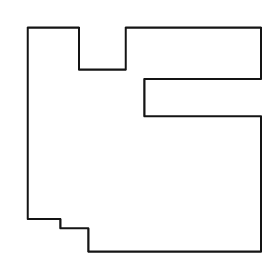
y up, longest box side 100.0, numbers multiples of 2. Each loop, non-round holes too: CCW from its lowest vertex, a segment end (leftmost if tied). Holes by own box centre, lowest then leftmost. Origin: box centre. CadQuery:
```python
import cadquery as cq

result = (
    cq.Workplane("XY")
    .moveTo(-24.0, -48.0)
    .lineTo(50.0, -48.0)
    .lineTo(50.0, 10.0)
    .lineTo(0.0, 10.0)
    .lineTo(0.0, 26.0)
    .lineTo(50.0, 26.0)
    .lineTo(50.0, 48.0)
    .lineTo(-8.0, 48.0)
    .lineTo(-8.0, 30.0)
    .lineTo(-28.0, 30.0)
    .lineTo(-28.0, 48.0)
    .lineTo(-50.0, 48.0)
    .lineTo(-50.0, -34.0)
    .lineTo(-36.0, -34.0)
    .lineTo(-36.0, -38.0)
    .lineTo(-24.0, -38.0)
    .close()
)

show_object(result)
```